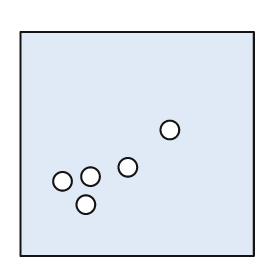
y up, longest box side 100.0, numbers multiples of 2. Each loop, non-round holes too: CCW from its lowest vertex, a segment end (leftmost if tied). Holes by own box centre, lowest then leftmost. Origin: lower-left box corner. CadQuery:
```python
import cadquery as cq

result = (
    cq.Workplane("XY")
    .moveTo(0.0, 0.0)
    .lineTo(100.0, 0.0)
    .lineTo(100.0, 96.0)
    .lineTo(0.0, 96.0)
    .close()
    .moveTo(28.0, 22.0)
    .circle(4.0)
    .moveTo(18.0, 32.0)
    .circle(4.0)
    .moveTo(30.0, 34.0)
    .circle(4.0)
    .moveTo(46.0, 38.0)
    .circle(4.0)
    .moveTo(64.0, 54.0)
    .circle(4.0)
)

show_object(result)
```